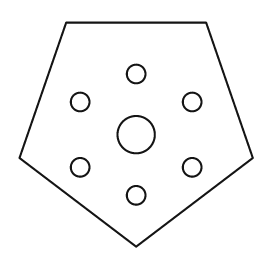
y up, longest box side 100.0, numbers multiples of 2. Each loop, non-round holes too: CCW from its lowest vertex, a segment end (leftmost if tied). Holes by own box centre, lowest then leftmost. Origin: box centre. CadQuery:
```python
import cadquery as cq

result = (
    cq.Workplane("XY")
    .moveTo(0.0, -48.0)
    .lineTo(50.0, -10.0)
    .lineTo(30.0, 48.0)
    .lineTo(-30.0, 48.0)
    .lineTo(-50.0, -10.0)
    .close()
    .moveTo(0.0, -26.0)
    .circle(4.0)
    .moveTo(-24.0, -14.0)
    .circle(4.0)
    .moveTo(24.0, -14.0)
    .circle(4.0)
    .moveTo(0.0, 0.0)
    .circle(8.0)
    .moveTo(-24.0, 14.0)
    .circle(4.0)
    .moveTo(24.0, 14.0)
    .circle(4.0)
    .moveTo(0.0, 26.0)
    .circle(4.0)
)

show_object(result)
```